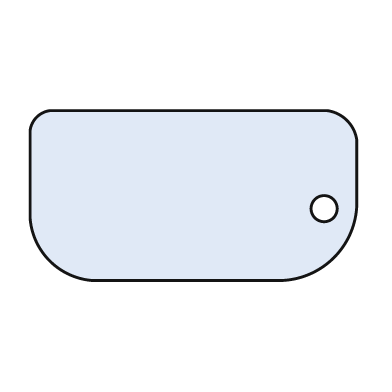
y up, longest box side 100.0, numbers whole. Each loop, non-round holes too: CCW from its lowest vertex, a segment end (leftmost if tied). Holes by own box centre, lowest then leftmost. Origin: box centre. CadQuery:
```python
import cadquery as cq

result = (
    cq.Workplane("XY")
    .moveTo(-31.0, -26.0)
    .lineTo(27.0, -26.0)
    .threePointArc((43.0, -19.0), (50.0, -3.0))
    .lineTo(50.0, 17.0)
    .threePointArc((47.0, 23.0), (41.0, 26.0))
    .lineTo(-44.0, 26.0)
    .threePointArc((-48.0, 24.0), (-50.0, 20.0))
    .lineTo(-50.0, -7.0)
    .threePointArc((-44.0, -20.0), (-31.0, -26.0))
    .close()
    .moveTo(40.0, -4.0)
    .circle(4.0)
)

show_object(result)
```